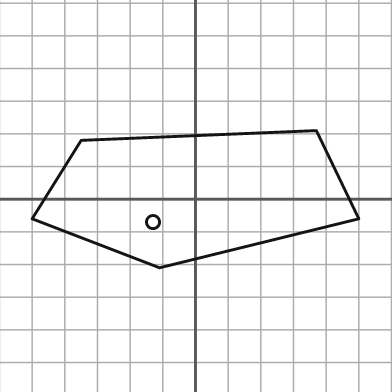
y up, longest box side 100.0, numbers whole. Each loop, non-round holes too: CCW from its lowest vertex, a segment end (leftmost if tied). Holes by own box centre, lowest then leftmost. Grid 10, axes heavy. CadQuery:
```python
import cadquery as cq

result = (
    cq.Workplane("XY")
    .moveTo(-11.0, -21.0)
    .lineTo(50.0, -6.0)
    .lineTo(37.0, 21.0)
    .lineTo(-35.0, 18.0)
    .lineTo(-50.0, -6.0)
    .close()
    .moveTo(-13.0, -7.0)
    .circle(2.0)
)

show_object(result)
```